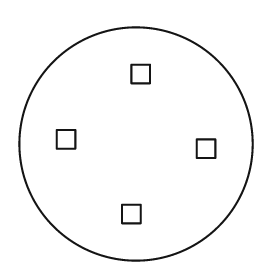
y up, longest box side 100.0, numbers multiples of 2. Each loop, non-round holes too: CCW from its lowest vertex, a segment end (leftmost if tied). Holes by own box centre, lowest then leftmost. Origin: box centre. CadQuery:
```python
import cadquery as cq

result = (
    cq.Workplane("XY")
    .moveTo(0.0, 0.0)
    .circle(50.0)
    .moveTo(-6.0, -34.0)
    .lineTo(2.0, -34.0)
    .lineTo(2.0, -26.0)
    .lineTo(-6.0, -26.0)
    .close()
    .moveTo(26.0, -6.0)
    .lineTo(34.0, -6.0)
    .lineTo(34.0, 2.0)
    .lineTo(26.0, 2.0)
    .close()
    .moveTo(-34.0, -2.0)
    .lineTo(-26.0, -2.0)
    .lineTo(-26.0, 6.0)
    .lineTo(-34.0, 6.0)
    .close()
    .moveTo(-2.0, 26.0)
    .lineTo(6.0, 26.0)
    .lineTo(6.0, 34.0)
    .lineTo(-2.0, 34.0)
    .close()
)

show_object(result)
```